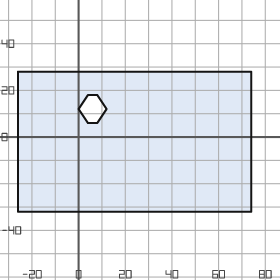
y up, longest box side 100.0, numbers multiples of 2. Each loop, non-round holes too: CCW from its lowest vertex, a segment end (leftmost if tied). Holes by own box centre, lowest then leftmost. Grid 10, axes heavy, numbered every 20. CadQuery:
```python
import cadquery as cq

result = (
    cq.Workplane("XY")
    .moveTo(-26.0, -32.0)
    .lineTo(74.0, -32.0)
    .lineTo(74.0, 28.0)
    .lineTo(-26.0, 28.0)
    .close()
    .moveTo(4.0, 6.0)
    .lineTo(8.0, 6.0)
    .lineTo(12.0, 12.0)
    .lineTo(8.0, 18.0)
    .lineTo(4.0, 18.0)
    .lineTo(0.0, 12.0)
    .close()
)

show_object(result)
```